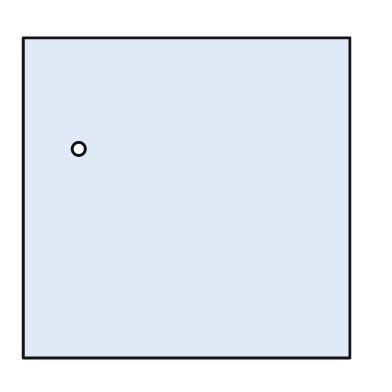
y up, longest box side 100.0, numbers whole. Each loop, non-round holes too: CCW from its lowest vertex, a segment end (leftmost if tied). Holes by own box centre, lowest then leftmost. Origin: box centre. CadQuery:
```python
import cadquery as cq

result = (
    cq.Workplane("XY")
    .moveTo(-50.0, -49.0)
    .lineTo(50.0, -49.0)
    .lineTo(50.0, 49.0)
    .lineTo(-50.0, 49.0)
    .close()
    .moveTo(-33.0, 15.0)
    .circle(2.0)
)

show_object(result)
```